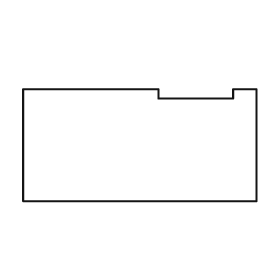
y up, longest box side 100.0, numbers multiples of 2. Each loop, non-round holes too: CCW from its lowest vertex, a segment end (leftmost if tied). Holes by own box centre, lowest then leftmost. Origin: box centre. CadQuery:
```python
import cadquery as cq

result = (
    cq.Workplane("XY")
    .moveTo(-50.0, -24.0)
    .lineTo(50.0, -24.0)
    .lineTo(50.0, 24.0)
    .lineTo(40.0, 24.0)
    .lineTo(40.0, 20.0)
    .lineTo(8.0, 20.0)
    .lineTo(8.0, 24.0)
    .lineTo(-50.0, 24.0)
    .close()
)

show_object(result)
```